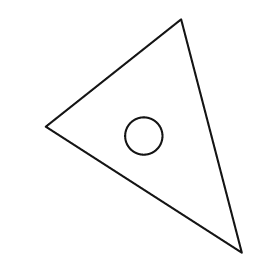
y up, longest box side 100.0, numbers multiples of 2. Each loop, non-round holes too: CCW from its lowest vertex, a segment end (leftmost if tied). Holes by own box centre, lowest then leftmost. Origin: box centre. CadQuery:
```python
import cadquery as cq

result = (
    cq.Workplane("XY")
    .moveTo(42.0, -50.0)
    .lineTo(16.0, 50.0)
    .lineTo(-42.0, 4.0)
    .close()
    .moveTo(0.0, 0.0)
    .circle(8.0)
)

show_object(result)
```